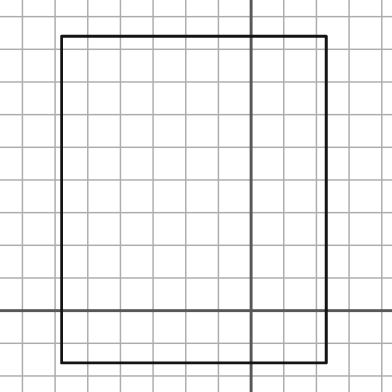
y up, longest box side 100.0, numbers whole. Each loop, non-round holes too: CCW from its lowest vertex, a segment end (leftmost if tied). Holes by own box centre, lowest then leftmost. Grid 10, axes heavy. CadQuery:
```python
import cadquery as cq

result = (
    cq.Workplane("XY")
    .moveTo(-58.0, -16.0)
    .lineTo(23.0, -16.0)
    .lineTo(23.0, 84.0)
    .lineTo(-58.0, 84.0)
    .close()
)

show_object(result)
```